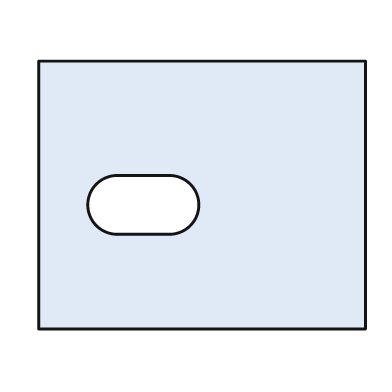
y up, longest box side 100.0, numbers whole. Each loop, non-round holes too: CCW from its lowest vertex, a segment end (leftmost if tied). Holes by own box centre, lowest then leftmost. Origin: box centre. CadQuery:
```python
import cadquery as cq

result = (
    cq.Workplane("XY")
    .moveTo(-50.0, -41.0)
    .lineTo(50.0, -41.0)
    .lineTo(50.0, 41.0)
    .lineTo(-50.0, 41.0)
    .close()
    .moveTo(-26.0, -12.0)
    .lineTo(-10.0, -12.0)
    .threePointArc((-1.0, -3.0), (-10.0, 6.0))
    .lineTo(-26.0, 6.0)
    .threePointArc((-35.0, -3.0), (-26.0, -12.0))
    .close()
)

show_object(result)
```